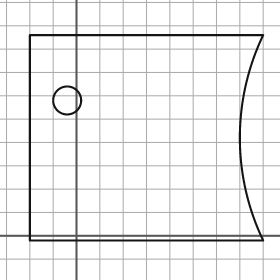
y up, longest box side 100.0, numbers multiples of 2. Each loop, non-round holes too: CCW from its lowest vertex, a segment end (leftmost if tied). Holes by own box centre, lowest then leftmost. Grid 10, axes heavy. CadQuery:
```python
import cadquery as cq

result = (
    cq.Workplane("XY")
    .moveTo(-20.0, -2.0)
    .lineTo(80.0, -2.0)
    .threePointArc((70.0, 42.0), (80.0, 86.0))
    .lineTo(-20.0, 86.0)
    .close()
    .moveTo(-4.0, 58.0)
    .circle(6.0)
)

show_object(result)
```